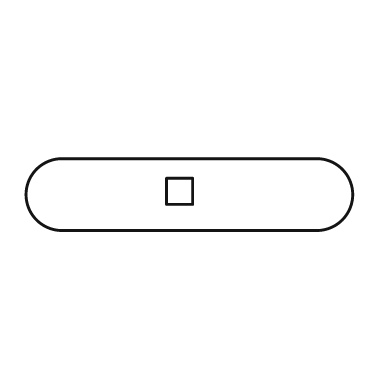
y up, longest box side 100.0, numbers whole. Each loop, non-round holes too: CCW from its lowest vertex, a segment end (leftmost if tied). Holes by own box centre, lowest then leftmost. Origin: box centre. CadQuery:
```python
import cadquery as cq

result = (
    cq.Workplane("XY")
    .moveTo(-39.0, -11.0)
    .lineTo(39.0, -11.0)
    .threePointArc((50.0, 0.0), (39.0, 11.0))
    .lineTo(-39.0, 11.0)
    .threePointArc((-50.0, 0.0), (-39.0, -11.0))
    .close()
    .moveTo(-7.0, -3.0)
    .lineTo(1.0, -3.0)
    .lineTo(1.0, 5.0)
    .lineTo(-7.0, 5.0)
    .close()
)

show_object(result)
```